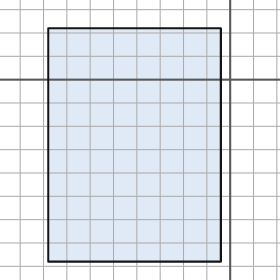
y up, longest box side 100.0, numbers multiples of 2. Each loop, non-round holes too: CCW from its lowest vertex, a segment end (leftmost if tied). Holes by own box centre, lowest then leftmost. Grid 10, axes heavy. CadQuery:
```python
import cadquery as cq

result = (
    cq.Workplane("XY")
    .moveTo(-78.0, -78.0)
    .lineTo(-4.0, -78.0)
    .lineTo(-4.0, 22.0)
    .lineTo(-78.0, 22.0)
    .close()
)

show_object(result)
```